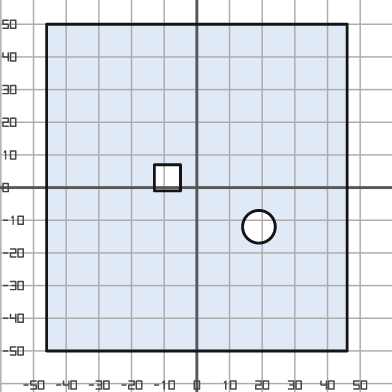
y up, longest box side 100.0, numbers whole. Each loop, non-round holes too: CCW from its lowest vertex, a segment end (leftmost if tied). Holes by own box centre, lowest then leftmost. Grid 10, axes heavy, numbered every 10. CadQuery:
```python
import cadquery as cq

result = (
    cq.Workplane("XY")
    .moveTo(-46.0, -50.0)
    .lineTo(46.0, -50.0)
    .lineTo(46.0, 50.0)
    .lineTo(-46.0, 50.0)
    .close()
    .moveTo(19.0, -12.0)
    .circle(5.0)
    .moveTo(-13.0, -1.0)
    .lineTo(-5.0, -1.0)
    .lineTo(-5.0, 7.0)
    .lineTo(-13.0, 7.0)
    .close()
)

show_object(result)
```